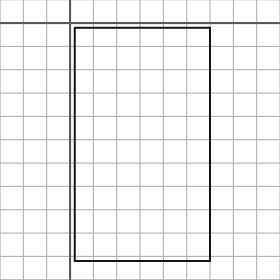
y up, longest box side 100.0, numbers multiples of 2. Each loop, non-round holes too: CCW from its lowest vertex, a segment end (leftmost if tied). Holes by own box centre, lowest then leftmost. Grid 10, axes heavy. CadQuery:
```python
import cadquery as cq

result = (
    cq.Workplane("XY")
    .moveTo(2.0, -102.0)
    .lineTo(60.0, -102.0)
    .lineTo(60.0, -2.0)
    .lineTo(2.0, -2.0)
    .close()
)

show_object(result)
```